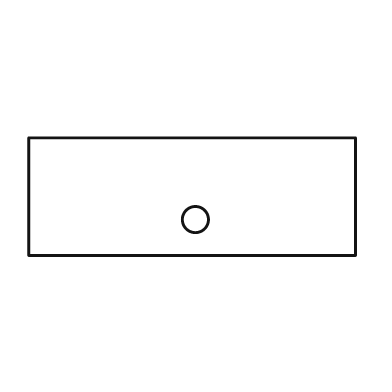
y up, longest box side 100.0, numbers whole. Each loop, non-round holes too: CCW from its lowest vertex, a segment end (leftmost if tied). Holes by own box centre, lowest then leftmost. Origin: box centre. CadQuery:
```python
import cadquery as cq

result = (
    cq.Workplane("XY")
    .moveTo(-50.0, -18.0)
    .lineTo(50.0, -18.0)
    .lineTo(50.0, 18.0)
    .lineTo(-50.0, 18.0)
    .close()
    .moveTo(1.0, -7.0)
    .circle(4.0)
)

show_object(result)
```